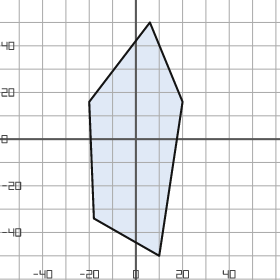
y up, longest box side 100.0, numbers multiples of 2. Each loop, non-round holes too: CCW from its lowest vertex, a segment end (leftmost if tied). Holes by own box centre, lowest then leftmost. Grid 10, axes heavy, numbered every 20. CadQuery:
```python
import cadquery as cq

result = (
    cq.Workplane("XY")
    .moveTo(10.0, -50.0)
    .lineTo(20.0, 16.0)
    .lineTo(6.0, 50.0)
    .lineTo(-20.0, 16.0)
    .lineTo(-18.0, -34.0)
    .close()
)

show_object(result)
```